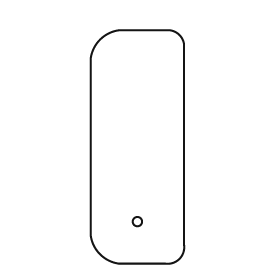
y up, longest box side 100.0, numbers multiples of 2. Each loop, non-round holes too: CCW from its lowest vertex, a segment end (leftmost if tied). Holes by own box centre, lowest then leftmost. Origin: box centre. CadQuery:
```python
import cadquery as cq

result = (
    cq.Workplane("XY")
    .moveTo(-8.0, -50.0)
    .lineTo(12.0, -50.0)
    .threePointArc((18.0, -48.0), (20.0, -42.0))
    .lineTo(20.0, 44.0)
    .threePointArc((18.0, 48.0), (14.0, 50.0))
    .lineTo(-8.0, 50.0)
    .threePointArc((-16.0, 46.0), (-20.0, 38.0))
    .lineTo(-20.0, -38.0)
    .threePointArc((-16.0, -46.0), (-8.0, -50.0))
    .close()
    .moveTo(0.0, -32.0)
    .circle(2.0)
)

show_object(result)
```